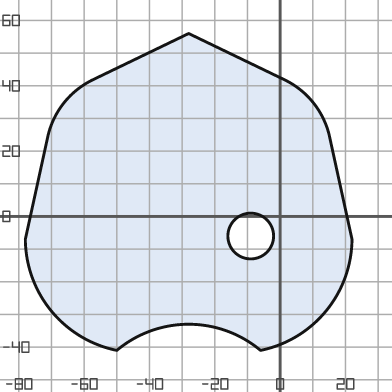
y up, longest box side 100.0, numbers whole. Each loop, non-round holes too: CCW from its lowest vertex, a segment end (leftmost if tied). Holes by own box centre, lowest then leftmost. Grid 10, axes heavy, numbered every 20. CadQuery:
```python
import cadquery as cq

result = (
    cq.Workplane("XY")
    .moveTo(-50.0, -41.0)
    .threePointArc((-28.0, -33.0), (-6.0, -41.0))
    .threePointArc((14.0, -29.0), (22.0, -7.0))
    .lineTo(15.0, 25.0)
    .threePointArc((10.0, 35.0), (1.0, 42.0))
    .lineTo(-28.0, 56.0)
    .lineTo(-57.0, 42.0)
    .threePointArc((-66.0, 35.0), (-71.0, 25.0))
    .lineTo(-78.0, -7.0)
    .threePointArc((-70.0, -29.0), (-50.0, -41.0))
    .close()
    .moveTo(-9.0, -6.0)
    .circle(7.0)
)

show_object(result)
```